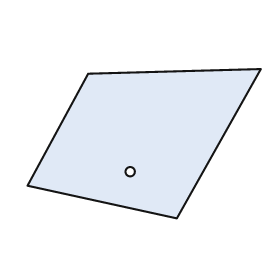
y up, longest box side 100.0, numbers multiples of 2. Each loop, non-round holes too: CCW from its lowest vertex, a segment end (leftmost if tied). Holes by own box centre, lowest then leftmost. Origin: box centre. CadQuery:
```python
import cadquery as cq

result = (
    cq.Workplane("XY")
    .moveTo(14.0, -32.0)
    .lineTo(50.0, 32.0)
    .lineTo(-24.0, 30.0)
    .lineTo(-50.0, -18.0)
    .close()
    .moveTo(-6.0, -12.0)
    .circle(2.0)
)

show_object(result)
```